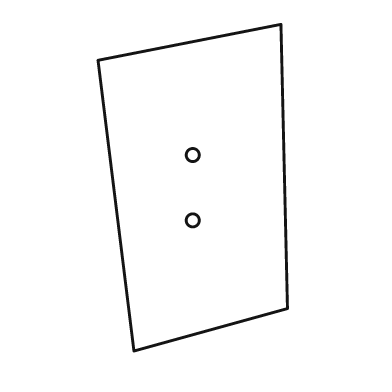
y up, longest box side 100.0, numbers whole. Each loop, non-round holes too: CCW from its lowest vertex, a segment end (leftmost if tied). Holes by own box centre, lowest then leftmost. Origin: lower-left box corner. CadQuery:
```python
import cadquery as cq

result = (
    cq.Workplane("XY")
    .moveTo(11.0, 0.0)
    .lineTo(58.0, 13.0)
    .lineTo(56.0, 100.0)
    .lineTo(0.0, 89.0)
    .close()
    .moveTo(29.0, 40.0)
    .circle(2.0)
    .moveTo(29.0, 60.0)
    .circle(2.0)
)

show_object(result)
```